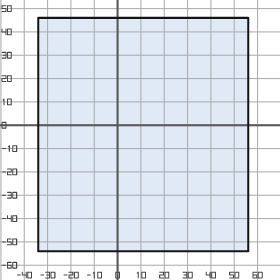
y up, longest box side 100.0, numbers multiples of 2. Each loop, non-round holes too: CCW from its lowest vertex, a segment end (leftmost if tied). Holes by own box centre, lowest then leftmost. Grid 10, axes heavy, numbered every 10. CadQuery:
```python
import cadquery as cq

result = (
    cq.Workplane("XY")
    .moveTo(-34.0, -54.0)
    .lineTo(56.0, -54.0)
    .lineTo(56.0, 46.0)
    .lineTo(-34.0, 46.0)
    .close()
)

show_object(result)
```